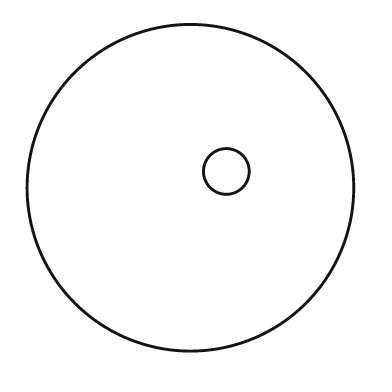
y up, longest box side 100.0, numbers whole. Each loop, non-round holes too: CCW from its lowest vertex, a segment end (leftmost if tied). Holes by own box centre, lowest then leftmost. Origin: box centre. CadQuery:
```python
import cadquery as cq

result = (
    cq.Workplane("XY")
    .moveTo(0.0, 0.0)
    .circle(50.0)
    .moveTo(11.0, 5.0)
    .circle(7.0)
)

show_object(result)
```